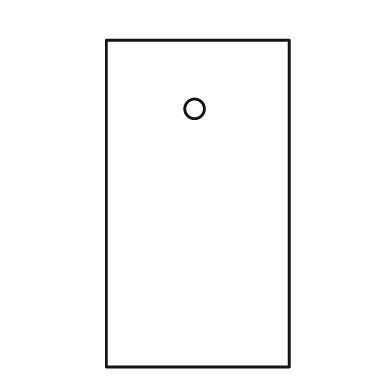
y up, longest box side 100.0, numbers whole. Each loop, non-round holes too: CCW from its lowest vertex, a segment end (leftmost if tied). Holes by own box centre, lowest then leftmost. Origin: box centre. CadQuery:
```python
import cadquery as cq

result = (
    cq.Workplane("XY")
    .moveTo(-28.0, -50.0)
    .lineTo(28.0, -50.0)
    .lineTo(28.0, 50.0)
    .lineTo(-28.0, 50.0)
    .close()
    .moveTo(-1.0, 29.0)
    .circle(3.0)
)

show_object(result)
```